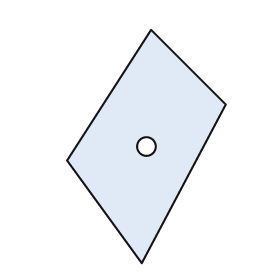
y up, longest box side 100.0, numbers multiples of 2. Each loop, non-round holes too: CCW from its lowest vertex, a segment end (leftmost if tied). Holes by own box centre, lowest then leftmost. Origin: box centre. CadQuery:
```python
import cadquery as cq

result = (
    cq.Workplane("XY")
    .moveTo(-2.0, -50.0)
    .lineTo(34.0, 18.0)
    .lineTo(2.0, 50.0)
    .lineTo(-34.0, -6.0)
    .close()
    .moveTo(0.0, 0.0)
    .circle(4.0)
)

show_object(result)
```